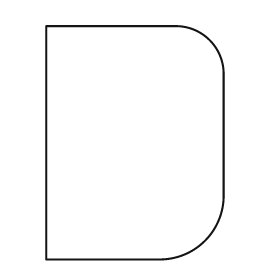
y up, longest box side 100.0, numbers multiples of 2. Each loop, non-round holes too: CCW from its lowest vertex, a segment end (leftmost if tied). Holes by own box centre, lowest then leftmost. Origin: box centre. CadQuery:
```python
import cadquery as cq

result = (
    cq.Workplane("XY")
    .moveTo(-38.0, -50.0)
    .lineTo(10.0, -50.0)
    .threePointArc((30.0, -42.0), (38.0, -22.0))
    .lineTo(38.0, 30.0)
    .threePointArc((32.0, 44.0), (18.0, 50.0))
    .lineTo(-38.0, 50.0)
    .close()
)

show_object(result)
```